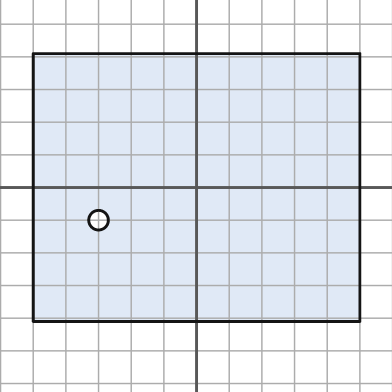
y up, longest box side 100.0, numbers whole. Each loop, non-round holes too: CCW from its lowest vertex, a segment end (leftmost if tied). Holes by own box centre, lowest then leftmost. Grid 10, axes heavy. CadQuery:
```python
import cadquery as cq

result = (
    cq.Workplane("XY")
    .moveTo(-50.0, -41.0)
    .lineTo(50.0, -41.0)
    .lineTo(50.0, 41.0)
    .lineTo(-50.0, 41.0)
    .close()
    .moveTo(-30.0, -10.0)
    .circle(3.0)
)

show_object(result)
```